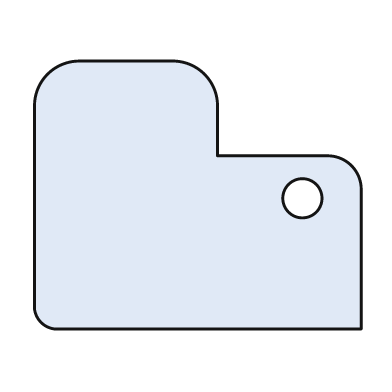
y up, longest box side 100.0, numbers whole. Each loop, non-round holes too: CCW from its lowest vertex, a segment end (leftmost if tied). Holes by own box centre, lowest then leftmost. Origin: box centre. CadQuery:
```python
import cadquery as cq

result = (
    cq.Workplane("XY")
    .moveTo(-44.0, -41.0)
    .lineTo(50.0, -41.0)
    .lineTo(50.0, 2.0)
    .threePointArc((47.0, 9.0), (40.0, 12.0))
    .lineTo(6.0, 12.0)
    .lineTo(6.0, 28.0)
    .threePointArc((2.0, 37.0), (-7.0, 41.0))
    .lineTo(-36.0, 41.0)
    .threePointArc((-46.0, 37.0), (-50.0, 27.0))
    .lineTo(-50.0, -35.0)
    .threePointArc((-48.0, -39.0), (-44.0, -41.0))
    .close()
    .moveTo(32.0, -1.0)
    .circle(6.0)
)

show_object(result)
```